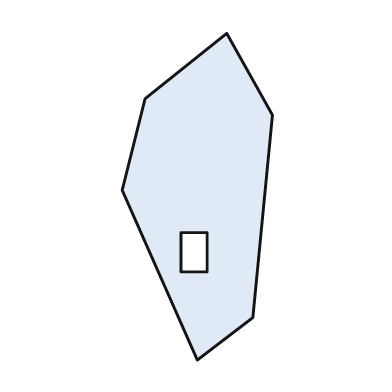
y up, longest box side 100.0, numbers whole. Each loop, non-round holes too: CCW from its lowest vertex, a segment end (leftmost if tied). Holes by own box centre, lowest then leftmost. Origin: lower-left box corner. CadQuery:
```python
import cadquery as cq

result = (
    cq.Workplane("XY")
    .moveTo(23.0, 0.0)
    .lineTo(40.0, 13.0)
    .lineTo(46.0, 75.0)
    .lineTo(32.0, 100.0)
    .lineTo(7.0, 80.0)
    .lineTo(0.0, 52.0)
    .close()
    .moveTo(18.0, 27.0)
    .lineTo(26.0, 27.0)
    .lineTo(26.0, 39.0)
    .lineTo(18.0, 39.0)
    .close()
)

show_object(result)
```